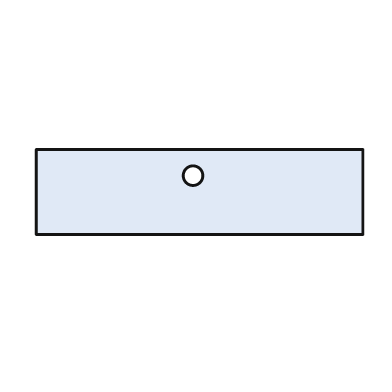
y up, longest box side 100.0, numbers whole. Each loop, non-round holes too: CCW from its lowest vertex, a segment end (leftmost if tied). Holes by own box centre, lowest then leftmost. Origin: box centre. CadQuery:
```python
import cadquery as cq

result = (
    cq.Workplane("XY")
    .moveTo(-50.0, -13.0)
    .lineTo(50.0, -13.0)
    .lineTo(50.0, 13.0)
    .lineTo(-50.0, 13.0)
    .close()
    .moveTo(-2.0, 5.0)
    .circle(3.0)
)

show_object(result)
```